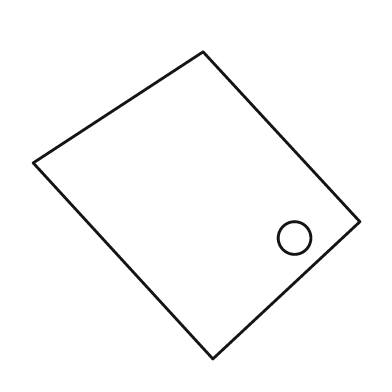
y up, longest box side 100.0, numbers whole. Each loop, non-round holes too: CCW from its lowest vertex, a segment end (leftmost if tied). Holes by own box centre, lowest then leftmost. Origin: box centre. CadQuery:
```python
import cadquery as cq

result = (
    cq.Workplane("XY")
    .moveTo(5.0, -47.0)
    .lineTo(50.0, -5.0)
    .lineTo(2.0, 47.0)
    .lineTo(-50.0, 13.0)
    .close()
    .moveTo(30.0, -10.0)
    .circle(5.0)
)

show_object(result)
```